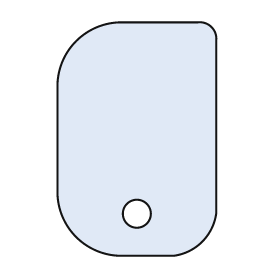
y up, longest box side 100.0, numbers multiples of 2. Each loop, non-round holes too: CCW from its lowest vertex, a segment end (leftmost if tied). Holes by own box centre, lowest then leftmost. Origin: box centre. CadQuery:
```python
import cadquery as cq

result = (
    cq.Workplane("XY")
    .moveTo(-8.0, -50.0)
    .lineTo(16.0, -50.0)
    .threePointArc((28.0, -44.0), (34.0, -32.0))
    .lineTo(34.0, 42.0)
    .threePointArc((32.0, 48.0), (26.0, 50.0))
    .lineTo(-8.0, 50.0)
    .threePointArc((-26.0, 42.0), (-34.0, 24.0))
    .lineTo(-34.0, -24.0)
    .threePointArc((-26.0, -42.0), (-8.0, -50.0))
    .close()
    .moveTo(0.0, -32.0)
    .circle(6.0)
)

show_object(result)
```